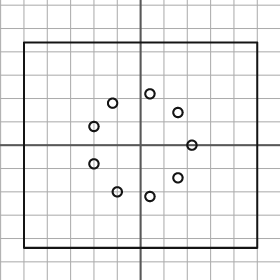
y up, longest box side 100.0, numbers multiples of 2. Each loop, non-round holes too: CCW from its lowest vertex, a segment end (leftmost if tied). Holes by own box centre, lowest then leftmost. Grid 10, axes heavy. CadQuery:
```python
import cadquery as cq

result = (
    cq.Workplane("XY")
    .moveTo(-50.0, -44.0)
    .lineTo(50.0, -44.0)
    .lineTo(50.0, 44.0)
    .lineTo(-50.0, 44.0)
    .close()
    .moveTo(4.0, -22.0)
    .circle(2.0)
    .moveTo(-10.0, -20.0)
    .circle(2.0)
    .moveTo(16.0, -14.0)
    .circle(2.0)
    .moveTo(-20.0, -8.0)
    .circle(2.0)
    .moveTo(22.0, 0.0)
    .circle(2.0)
    .moveTo(-20.0, 8.0)
    .circle(2.0)
    .moveTo(16.0, 14.0)
    .circle(2.0)
    .moveTo(-12.0, 18.0)
    .circle(2.0)
    .moveTo(4.0, 22.0)
    .circle(2.0)
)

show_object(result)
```